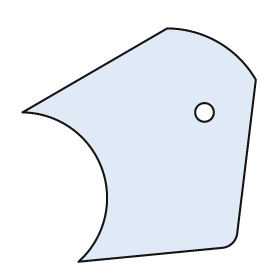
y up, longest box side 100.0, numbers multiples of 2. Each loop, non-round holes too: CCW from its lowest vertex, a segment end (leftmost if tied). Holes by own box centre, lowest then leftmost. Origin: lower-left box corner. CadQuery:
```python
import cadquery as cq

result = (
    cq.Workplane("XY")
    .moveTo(24.0, 0.0)
    .lineTo(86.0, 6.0)
    .threePointArc((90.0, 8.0), (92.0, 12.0))
    .lineTo(100.0, 78.0)
    .threePointArc((84.0, 94.0), (62.0, 100.0))
    .lineTo(0.0, 64.0)
    .threePointArc((34.0, 40.0), (24.0, 0.0))
    .close()
    .moveTo(78.0, 64.0)
    .circle(4.0)
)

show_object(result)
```